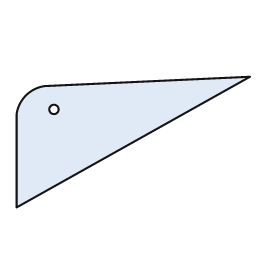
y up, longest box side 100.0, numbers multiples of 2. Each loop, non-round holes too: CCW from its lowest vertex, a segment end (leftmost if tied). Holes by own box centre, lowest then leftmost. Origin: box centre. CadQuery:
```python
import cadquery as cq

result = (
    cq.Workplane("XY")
    .moveTo(-50.0, -28.0)
    .lineTo(50.0, 28.0)
    .lineTo(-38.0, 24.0)
    .threePointArc((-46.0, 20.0), (-50.0, 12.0))
    .close()
    .moveTo(-34.0, 14.0)
    .circle(2.0)
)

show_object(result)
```